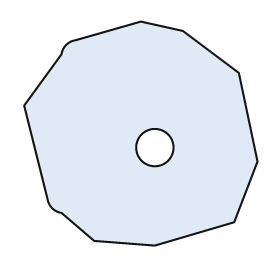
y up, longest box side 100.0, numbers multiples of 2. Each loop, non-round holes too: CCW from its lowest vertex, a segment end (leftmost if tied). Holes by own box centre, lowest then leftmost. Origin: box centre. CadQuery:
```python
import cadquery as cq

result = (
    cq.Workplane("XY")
    .moveTo(6.0, -48.0)
    .lineTo(40.0, -38.0)
    .lineTo(50.0, -12.0)
    .lineTo(42.0, 26.0)
    .lineTo(18.0, 44.0)
    .lineTo(0.0, 48.0)
    .lineTo(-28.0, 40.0)
    .threePointArc((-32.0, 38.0), (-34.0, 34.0))
    .lineTo(-50.0, 12.0)
    .lineTo(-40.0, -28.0)
    .threePointArc((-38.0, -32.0), (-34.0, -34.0))
    .lineTo(-20.0, -46.0)
    .close()
    .moveTo(6.0, -6.0)
    .circle(8.0)
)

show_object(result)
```